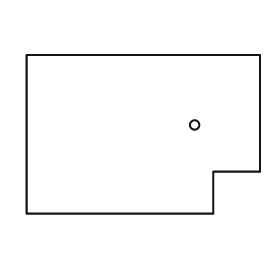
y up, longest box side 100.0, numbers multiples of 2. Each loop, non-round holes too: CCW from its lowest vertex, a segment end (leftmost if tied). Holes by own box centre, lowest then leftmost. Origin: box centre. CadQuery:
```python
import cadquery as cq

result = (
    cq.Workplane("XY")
    .moveTo(-50.0, -34.0)
    .lineTo(30.0, -34.0)
    .lineTo(30.0, -16.0)
    .lineTo(50.0, -16.0)
    .lineTo(50.0, 34.0)
    .lineTo(-50.0, 34.0)
    .close()
    .moveTo(22.0, 4.0)
    .circle(2.0)
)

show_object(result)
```